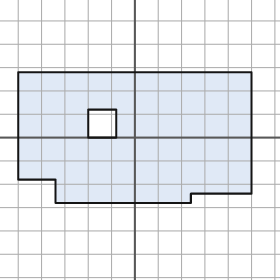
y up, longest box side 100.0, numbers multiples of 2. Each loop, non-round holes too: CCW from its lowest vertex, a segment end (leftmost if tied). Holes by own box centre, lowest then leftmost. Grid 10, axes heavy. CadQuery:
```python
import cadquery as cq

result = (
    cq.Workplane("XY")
    .moveTo(-34.0, -28.0)
    .lineTo(24.0, -28.0)
    .lineTo(24.0, -24.0)
    .lineTo(50.0, -24.0)
    .lineTo(50.0, 28.0)
    .lineTo(-50.0, 28.0)
    .lineTo(-50.0, -18.0)
    .lineTo(-34.0, -18.0)
    .close()
    .moveTo(-20.0, 0.0)
    .lineTo(-8.0, 0.0)
    .lineTo(-8.0, 12.0)
    .lineTo(-20.0, 12.0)
    .close()
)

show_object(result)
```